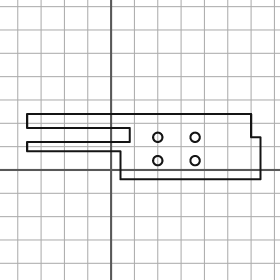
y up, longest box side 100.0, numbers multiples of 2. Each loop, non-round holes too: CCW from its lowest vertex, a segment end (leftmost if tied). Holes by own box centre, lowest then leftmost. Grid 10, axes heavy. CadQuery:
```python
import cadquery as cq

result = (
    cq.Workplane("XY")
    .moveTo(4.0, -4.0)
    .lineTo(64.0, -4.0)
    .lineTo(64.0, 14.0)
    .lineTo(60.0, 14.0)
    .lineTo(60.0, 24.0)
    .lineTo(-36.0, 24.0)
    .lineTo(-36.0, 18.0)
    .lineTo(8.0, 18.0)
    .lineTo(8.0, 12.0)
    .lineTo(-36.0, 12.0)
    .lineTo(-36.0, 8.0)
    .lineTo(4.0, 8.0)
    .close()
    .moveTo(20.0, 4.0)
    .circle(2.0)
    .moveTo(36.0, 4.0)
    .circle(2.0)
    .moveTo(20.0, 14.0)
    .circle(2.0)
    .moveTo(36.0, 14.0)
    .circle(2.0)
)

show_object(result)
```